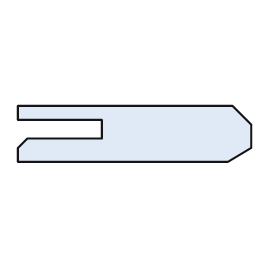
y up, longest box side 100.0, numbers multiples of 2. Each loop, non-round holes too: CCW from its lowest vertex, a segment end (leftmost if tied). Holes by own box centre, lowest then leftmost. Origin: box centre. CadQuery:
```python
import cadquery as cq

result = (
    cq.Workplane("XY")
    .moveTo(-50.0, -12.0)
    .lineTo(40.0, -12.0)
    .lineTo(50.0, -6.0)
    .lineTo(50.0, 4.0)
    .lineTo(42.0, 12.0)
    .lineTo(-50.0, 12.0)
    .lineTo(-50.0, 6.0)
    .lineTo(-14.0, 6.0)
    .lineTo(-14.0, -2.0)
    .lineTo(-46.0, -2.0)
    .lineTo(-50.0, -6.0)
    .close()
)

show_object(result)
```